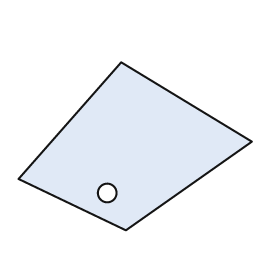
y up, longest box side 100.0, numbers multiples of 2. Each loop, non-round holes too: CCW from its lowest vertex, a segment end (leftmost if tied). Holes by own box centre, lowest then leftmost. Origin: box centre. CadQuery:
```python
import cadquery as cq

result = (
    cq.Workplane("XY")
    .moveTo(-4.0, -36.0)
    .lineTo(50.0, 2.0)
    .lineTo(-6.0, 36.0)
    .lineTo(-50.0, -14.0)
    .close()
    .moveTo(-12.0, -20.0)
    .circle(4.0)
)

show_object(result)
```